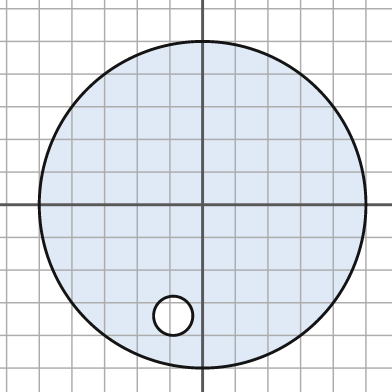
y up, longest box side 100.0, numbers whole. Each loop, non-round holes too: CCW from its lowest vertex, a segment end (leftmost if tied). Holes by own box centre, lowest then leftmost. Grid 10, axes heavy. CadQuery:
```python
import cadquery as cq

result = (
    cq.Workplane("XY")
    .moveTo(0.0, 0.0)
    .circle(50.0)
    .moveTo(-9.0, -34.0)
    .circle(6.0)
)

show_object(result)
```